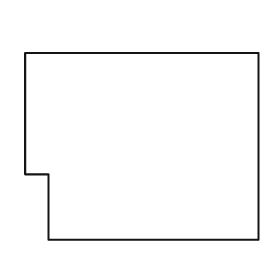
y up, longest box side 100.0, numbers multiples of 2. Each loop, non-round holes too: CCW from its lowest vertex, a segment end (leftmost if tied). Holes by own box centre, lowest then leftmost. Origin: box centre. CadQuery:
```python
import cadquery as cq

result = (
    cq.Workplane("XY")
    .moveTo(-40.0, -40.0)
    .lineTo(50.0, -40.0)
    .lineTo(50.0, 40.0)
    .lineTo(-50.0, 40.0)
    .lineTo(-50.0, -12.0)
    .lineTo(-40.0, -12.0)
    .close()
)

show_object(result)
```